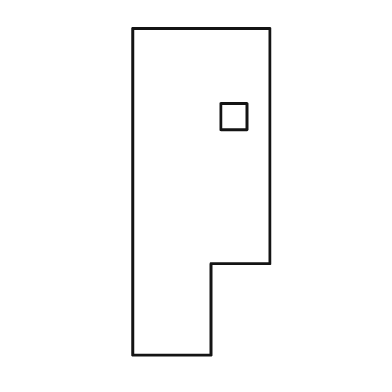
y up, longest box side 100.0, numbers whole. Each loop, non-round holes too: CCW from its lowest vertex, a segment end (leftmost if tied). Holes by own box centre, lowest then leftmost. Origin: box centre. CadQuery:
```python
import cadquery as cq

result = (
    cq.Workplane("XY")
    .moveTo(-21.0, -50.0)
    .lineTo(3.0, -50.0)
    .lineTo(3.0, -22.0)
    .lineTo(21.0, -22.0)
    .lineTo(21.0, 50.0)
    .lineTo(-21.0, 50.0)
    .close()
    .moveTo(6.0, 19.0)
    .lineTo(14.0, 19.0)
    .lineTo(14.0, 27.0)
    .lineTo(6.0, 27.0)
    .close()
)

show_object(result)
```